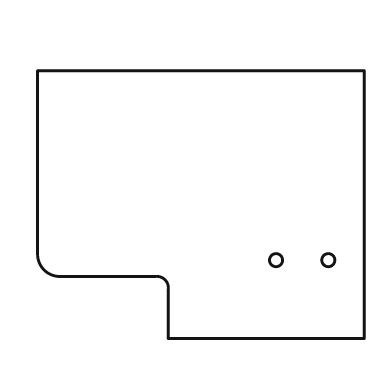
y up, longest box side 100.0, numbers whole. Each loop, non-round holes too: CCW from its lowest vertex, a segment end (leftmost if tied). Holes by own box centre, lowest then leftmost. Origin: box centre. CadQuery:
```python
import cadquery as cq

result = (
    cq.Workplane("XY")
    .moveTo(-10.0, -41.0)
    .lineTo(50.0, -41.0)
    .lineTo(50.0, 41.0)
    .lineTo(-50.0, 41.0)
    .lineTo(-50.0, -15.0)
    .threePointArc((-48.0, -20.0), (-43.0, -22.0))
    .lineTo(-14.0, -22.0)
    .threePointArc((-11.0, -23.0), (-10.0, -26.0))
    .close()
    .moveTo(23.0, -17.0)
    .circle(2.0)
    .moveTo(39.0, -17.0)
    .circle(2.0)
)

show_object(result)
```